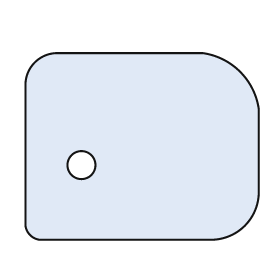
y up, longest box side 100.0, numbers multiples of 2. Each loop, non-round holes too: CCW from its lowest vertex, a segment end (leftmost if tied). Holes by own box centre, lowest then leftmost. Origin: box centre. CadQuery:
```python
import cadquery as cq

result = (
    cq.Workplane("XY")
    .moveTo(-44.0, -40.0)
    .lineTo(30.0, -40.0)
    .threePointArc((44.0, -34.0), (50.0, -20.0))
    .lineTo(50.0, 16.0)
    .threePointArc((42.0, 32.0), (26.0, 40.0))
    .lineTo(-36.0, 40.0)
    .threePointArc((-46.0, 36.0), (-50.0, 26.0))
    .lineTo(-50.0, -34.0)
    .threePointArc((-48.0, -38.0), (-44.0, -40.0))
    .close()
    .moveTo(-26.0, -8.0)
    .circle(6.0)
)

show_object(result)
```